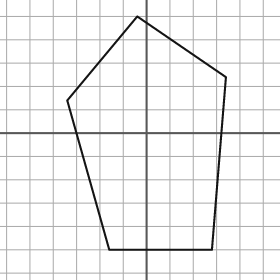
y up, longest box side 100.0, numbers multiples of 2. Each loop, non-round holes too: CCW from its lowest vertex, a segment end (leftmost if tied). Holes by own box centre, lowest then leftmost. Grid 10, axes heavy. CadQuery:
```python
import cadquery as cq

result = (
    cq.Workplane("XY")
    .moveTo(-16.0, -50.0)
    .lineTo(28.0, -50.0)
    .lineTo(34.0, 24.0)
    .lineTo(-4.0, 50.0)
    .lineTo(-34.0, 14.0)
    .close()
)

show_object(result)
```